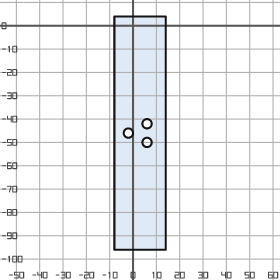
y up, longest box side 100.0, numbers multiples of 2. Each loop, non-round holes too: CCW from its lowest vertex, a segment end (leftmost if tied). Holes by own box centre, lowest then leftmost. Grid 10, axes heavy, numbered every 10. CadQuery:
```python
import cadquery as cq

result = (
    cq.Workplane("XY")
    .moveTo(-8.0, -96.0)
    .lineTo(14.0, -96.0)
    .lineTo(14.0, 4.0)
    .lineTo(-8.0, 4.0)
    .close()
    .moveTo(6.0, -50.0)
    .circle(2.0)
    .moveTo(-2.0, -46.0)
    .circle(2.0)
    .moveTo(6.0, -42.0)
    .circle(2.0)
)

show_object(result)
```